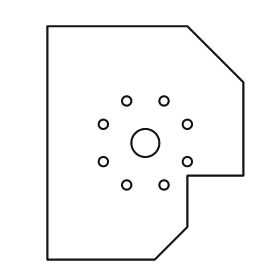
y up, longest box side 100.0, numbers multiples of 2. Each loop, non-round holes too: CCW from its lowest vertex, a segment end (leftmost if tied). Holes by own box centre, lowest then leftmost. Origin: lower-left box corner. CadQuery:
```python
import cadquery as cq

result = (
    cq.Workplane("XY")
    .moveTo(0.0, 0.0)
    .lineTo(46.0, 0.0)
    .lineTo(60.0, 14.0)
    .lineTo(60.0, 36.0)
    .lineTo(84.0, 36.0)
    .lineTo(84.0, 76.0)
    .lineTo(60.0, 100.0)
    .lineTo(0.0, 100.0)
    .close()
    .moveTo(34.0, 32.0)
    .circle(2.0)
    .moveTo(50.0, 32.0)
    .circle(2.0)
    .moveTo(24.0, 42.0)
    .circle(2.0)
    .moveTo(60.0, 42.0)
    .circle(2.0)
    .moveTo(42.0, 50.0)
    .circle(6.0)
    .moveTo(24.0, 58.0)
    .circle(2.0)
    .moveTo(60.0, 58.0)
    .circle(2.0)
    .moveTo(34.0, 68.0)
    .circle(2.0)
    .moveTo(50.0, 68.0)
    .circle(2.0)
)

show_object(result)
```